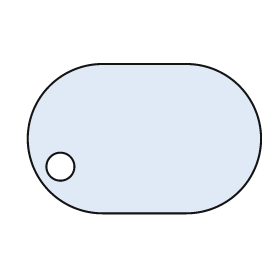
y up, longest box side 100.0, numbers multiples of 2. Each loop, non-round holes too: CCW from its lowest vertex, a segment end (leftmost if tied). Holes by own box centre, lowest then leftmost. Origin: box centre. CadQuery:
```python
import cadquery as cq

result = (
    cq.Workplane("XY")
    .moveTo(-18.0, -32.0)
    .lineTo(18.0, -32.0)
    .threePointArc((50.0, 0.0), (18.0, 32.0))
    .lineTo(-18.0, 32.0)
    .threePointArc((-50.0, 0.0), (-18.0, -32.0))
    .close()
    .moveTo(-36.0, -12.0)
    .circle(6.0)
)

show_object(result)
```